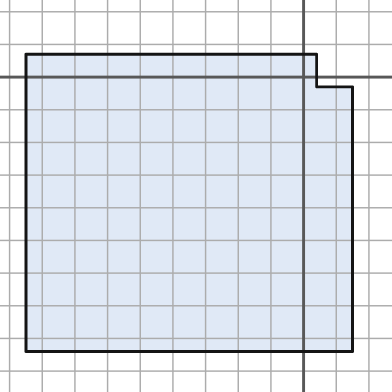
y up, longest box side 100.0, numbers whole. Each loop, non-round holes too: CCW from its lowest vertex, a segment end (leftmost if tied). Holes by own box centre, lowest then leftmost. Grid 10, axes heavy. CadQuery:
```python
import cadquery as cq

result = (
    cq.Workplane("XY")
    .moveTo(-85.0, -84.0)
    .lineTo(15.0, -84.0)
    .lineTo(15.0, -3.0)
    .lineTo(4.0, -3.0)
    .lineTo(4.0, 7.0)
    .lineTo(-85.0, 7.0)
    .close()
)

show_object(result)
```